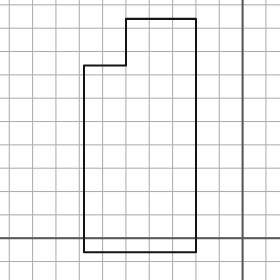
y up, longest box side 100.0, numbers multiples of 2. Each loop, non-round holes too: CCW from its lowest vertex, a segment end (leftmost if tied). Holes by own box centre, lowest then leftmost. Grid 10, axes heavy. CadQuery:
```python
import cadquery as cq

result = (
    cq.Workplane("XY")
    .moveTo(-68.0, -6.0)
    .lineTo(-20.0, -6.0)
    .lineTo(-20.0, 94.0)
    .lineTo(-50.0, 94.0)
    .lineTo(-50.0, 74.0)
    .lineTo(-68.0, 74.0)
    .close()
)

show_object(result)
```